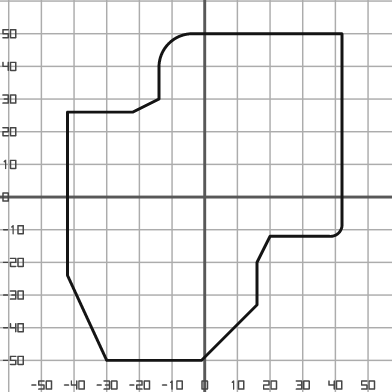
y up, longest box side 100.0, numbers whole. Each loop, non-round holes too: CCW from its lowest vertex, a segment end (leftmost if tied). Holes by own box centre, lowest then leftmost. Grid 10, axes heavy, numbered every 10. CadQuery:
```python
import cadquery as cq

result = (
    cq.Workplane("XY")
    .moveTo(-30.0, -50.0)
    .lineTo(-1.0, -50.0)
    .lineTo(16.0, -33.0)
    .lineTo(16.0, -20.0)
    .lineTo(20.0, -12.0)
    .lineTo(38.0, -12.0)
    .threePointArc((41.0, -11.0), (42.0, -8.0))
    .lineTo(42.0, 50.0)
    .lineTo(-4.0, 50.0)
    .threePointArc((-11.0, 47.0), (-14.0, 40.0))
    .lineTo(-14.0, 30.0)
    .lineTo(-22.0, 26.0)
    .lineTo(-42.0, 26.0)
    .lineTo(-42.0, -24.0)
    .close()
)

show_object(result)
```